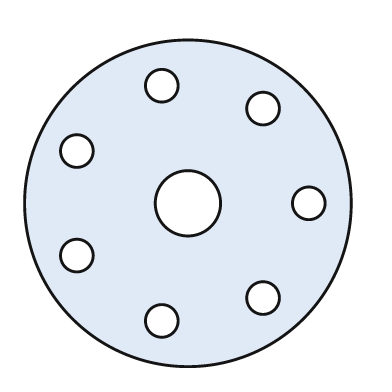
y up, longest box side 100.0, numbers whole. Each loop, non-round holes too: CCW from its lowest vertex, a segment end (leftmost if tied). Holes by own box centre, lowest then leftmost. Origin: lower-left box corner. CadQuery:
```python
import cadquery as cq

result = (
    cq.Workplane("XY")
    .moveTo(50.0, 50.0)
    .circle(50.0)
    .moveTo(42.0, 14.0)
    .circle(5.0)
    .moveTo(73.0, 21.0)
    .circle(5.0)
    .moveTo(16.0, 34.0)
    .circle(5.0)
    .moveTo(50.0, 50.0)
    .circle(10.0)
    .moveTo(87.0, 50.0)
    .circle(5.0)
    .moveTo(16.0, 66.0)
    .circle(5.0)
    .moveTo(73.0, 79.0)
    .circle(5.0)
    .moveTo(42.0, 86.0)
    .circle(5.0)
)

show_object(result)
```